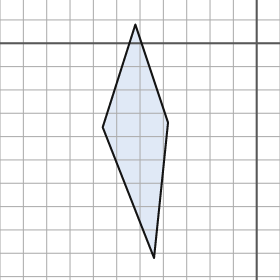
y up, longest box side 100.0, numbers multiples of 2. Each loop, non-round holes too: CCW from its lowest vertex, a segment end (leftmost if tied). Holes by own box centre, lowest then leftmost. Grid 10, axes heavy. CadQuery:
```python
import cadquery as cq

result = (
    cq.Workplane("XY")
    .moveTo(-44.0, -92.0)
    .lineTo(-38.0, -34.0)
    .lineTo(-52.0, 8.0)
    .lineTo(-66.0, -36.0)
    .close()
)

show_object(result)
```